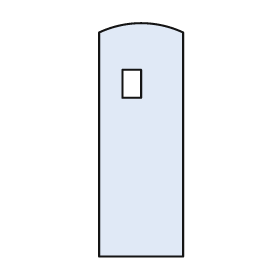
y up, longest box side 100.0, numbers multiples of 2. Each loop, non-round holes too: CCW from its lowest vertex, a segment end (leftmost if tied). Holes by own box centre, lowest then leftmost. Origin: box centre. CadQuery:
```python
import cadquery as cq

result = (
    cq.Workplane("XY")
    .moveTo(-18.0, -50.0)
    .lineTo(18.0, -50.0)
    .lineTo(18.0, 46.0)
    .threePointArc((0.0, 50.0), (-18.0, 46.0))
    .close()
    .moveTo(-8.0, 18.0)
    .lineTo(0.0, 18.0)
    .lineTo(0.0, 30.0)
    .lineTo(-8.0, 30.0)
    .close()
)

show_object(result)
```